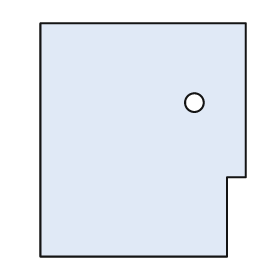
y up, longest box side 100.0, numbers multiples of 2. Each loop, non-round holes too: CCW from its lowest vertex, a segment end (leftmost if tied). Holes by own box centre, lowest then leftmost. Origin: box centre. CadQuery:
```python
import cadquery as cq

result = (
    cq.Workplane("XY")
    .moveTo(-44.0, -50.0)
    .lineTo(36.0, -50.0)
    .lineTo(36.0, -16.0)
    .lineTo(44.0, -16.0)
    .lineTo(44.0, 50.0)
    .lineTo(-44.0, 50.0)
    .close()
    .moveTo(22.0, 16.0)
    .circle(4.0)
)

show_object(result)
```